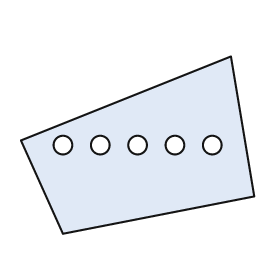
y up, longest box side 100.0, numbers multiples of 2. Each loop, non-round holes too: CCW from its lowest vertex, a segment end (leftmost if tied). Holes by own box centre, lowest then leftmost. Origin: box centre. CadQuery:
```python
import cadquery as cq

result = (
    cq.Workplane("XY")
    .moveTo(-32.0, -38.0)
    .lineTo(50.0, -22.0)
    .lineTo(40.0, 38.0)
    .lineTo(-50.0, 2.0)
    .close()
    .moveTo(-32.0, 0.0)
    .circle(4.0)
    .moveTo(-16.0, 0.0)
    .circle(4.0)
    .moveTo(0.0, 0.0)
    .circle(4.0)
    .moveTo(16.0, 0.0)
    .circle(4.0)
    .moveTo(32.0, 0.0)
    .circle(4.0)
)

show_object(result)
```